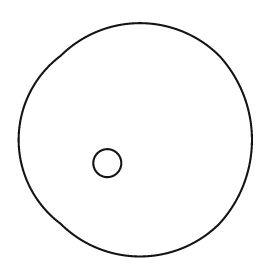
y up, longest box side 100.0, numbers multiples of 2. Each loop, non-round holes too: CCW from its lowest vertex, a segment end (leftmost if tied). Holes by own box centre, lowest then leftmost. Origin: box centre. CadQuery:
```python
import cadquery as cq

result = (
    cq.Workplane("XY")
    .moveTo(-32.0, -36.0)
    .threePointArc((2.0, -50.0), (36.0, -36.0))
    .threePointArc((50.0, 0.0), (36.0, 36.0))
    .threePointArc((2.0, 50.0), (-32.0, 36.0))
    .threePointArc((-50.0, 0.0), (-32.0, -36.0))
    .close()
    .moveTo(-12.0, -10.0)
    .circle(6.0)
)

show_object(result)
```